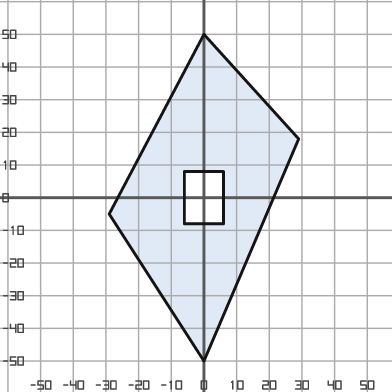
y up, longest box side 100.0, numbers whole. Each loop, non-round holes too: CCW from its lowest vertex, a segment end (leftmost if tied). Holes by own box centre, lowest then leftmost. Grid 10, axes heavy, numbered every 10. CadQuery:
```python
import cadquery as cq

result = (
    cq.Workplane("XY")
    .moveTo(0.0, -50.0)
    .lineTo(29.0, 18.0)
    .lineTo(0.0, 50.0)
    .lineTo(-29.0, -5.0)
    .close()
    .moveTo(-6.0, -8.0)
    .lineTo(6.0, -8.0)
    .lineTo(6.0, 8.0)
    .lineTo(-6.0, 8.0)
    .close()
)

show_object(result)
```